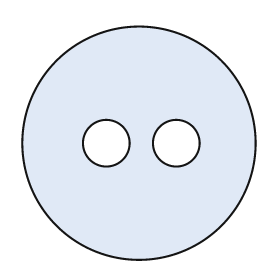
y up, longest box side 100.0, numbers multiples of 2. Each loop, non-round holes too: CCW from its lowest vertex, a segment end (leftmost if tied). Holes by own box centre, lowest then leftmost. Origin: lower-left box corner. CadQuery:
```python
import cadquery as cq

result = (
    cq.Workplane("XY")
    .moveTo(50.0, 50.0)
    .circle(50.0)
    .moveTo(36.0, 50.0)
    .circle(10.0)
    .moveTo(66.0, 50.0)
    .circle(10.0)
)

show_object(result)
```